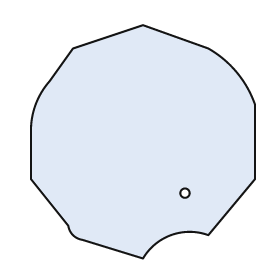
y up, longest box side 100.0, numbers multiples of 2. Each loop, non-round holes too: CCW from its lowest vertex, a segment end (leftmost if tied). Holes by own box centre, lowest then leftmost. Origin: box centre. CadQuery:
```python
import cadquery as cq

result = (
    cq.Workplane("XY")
    .moveTo(0.0, -50.0)
    .threePointArc((12.0, -40.0), (28.0, -40.0))
    .lineTo(48.0, -16.0)
    .lineTo(48.0, 16.0)
    .threePointArc((40.0, 30.0), (28.0, 40.0))
    .lineTo(0.0, 50.0)
    .lineTo(-30.0, 40.0)
    .lineTo(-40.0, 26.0)
    .threePointArc((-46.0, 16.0), (-48.0, 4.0))
    .lineTo(-48.0, -16.0)
    .lineTo(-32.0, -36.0)
    .threePointArc((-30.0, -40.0), (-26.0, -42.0))
    .close()
    .moveTo(18.0, -22.0)
    .circle(2.0)
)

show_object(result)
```